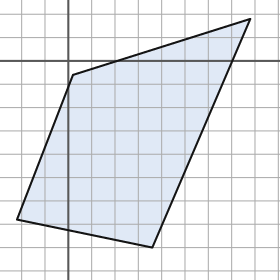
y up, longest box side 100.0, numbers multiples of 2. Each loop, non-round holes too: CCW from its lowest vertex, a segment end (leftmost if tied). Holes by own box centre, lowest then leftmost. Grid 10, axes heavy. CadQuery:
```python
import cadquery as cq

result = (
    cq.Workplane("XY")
    .moveTo(36.0, -80.0)
    .lineTo(78.0, 18.0)
    .lineTo(2.0, -6.0)
    .lineTo(-22.0, -68.0)
    .close()
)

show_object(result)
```